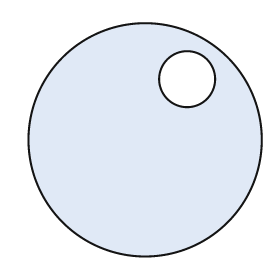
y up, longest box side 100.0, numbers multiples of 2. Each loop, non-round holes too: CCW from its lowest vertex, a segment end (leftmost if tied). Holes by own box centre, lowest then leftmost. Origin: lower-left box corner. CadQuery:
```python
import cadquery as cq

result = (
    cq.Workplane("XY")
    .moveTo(50.0, 50.0)
    .circle(50.0)
    .moveTo(68.0, 76.0)
    .circle(12.0)
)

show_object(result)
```